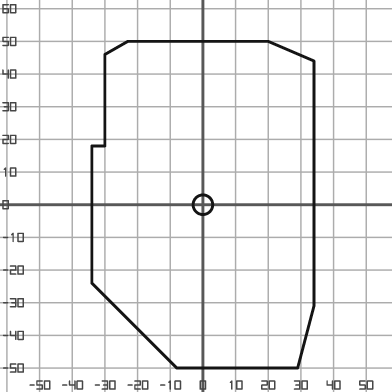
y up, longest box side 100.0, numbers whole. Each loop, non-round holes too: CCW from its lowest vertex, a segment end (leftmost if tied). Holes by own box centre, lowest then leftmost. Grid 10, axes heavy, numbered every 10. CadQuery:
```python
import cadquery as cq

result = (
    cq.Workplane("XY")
    .moveTo(-8.0, -50.0)
    .lineTo(29.0, -50.0)
    .lineTo(34.0, -31.0)
    .lineTo(34.0, 44.0)
    .lineTo(20.0, 50.0)
    .lineTo(-23.0, 50.0)
    .lineTo(-30.0, 46.0)
    .lineTo(-30.0, 18.0)
    .lineTo(-34.0, 18.0)
    .lineTo(-34.0, -24.0)
    .close()
    .moveTo(0.0, 0.0)
    .circle(3.0)
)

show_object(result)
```